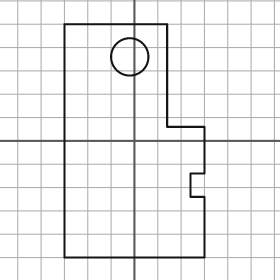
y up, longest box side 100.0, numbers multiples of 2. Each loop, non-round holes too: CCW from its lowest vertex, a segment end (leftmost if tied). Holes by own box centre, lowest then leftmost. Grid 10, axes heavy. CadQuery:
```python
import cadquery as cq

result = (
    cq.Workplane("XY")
    .moveTo(-30.0, -50.0)
    .lineTo(30.0, -50.0)
    .lineTo(30.0, -24.0)
    .lineTo(24.0, -24.0)
    .lineTo(24.0, -14.0)
    .lineTo(30.0, -14.0)
    .lineTo(30.0, 6.0)
    .lineTo(14.0, 6.0)
    .lineTo(14.0, 50.0)
    .lineTo(-30.0, 50.0)
    .close()
    .moveTo(-2.0, 36.0)
    .circle(8.0)
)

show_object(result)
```